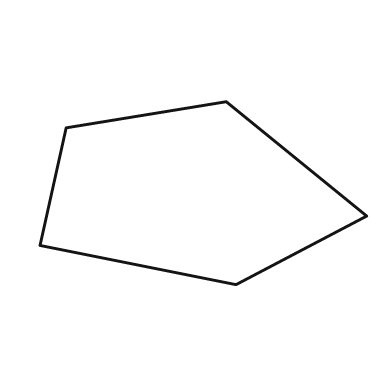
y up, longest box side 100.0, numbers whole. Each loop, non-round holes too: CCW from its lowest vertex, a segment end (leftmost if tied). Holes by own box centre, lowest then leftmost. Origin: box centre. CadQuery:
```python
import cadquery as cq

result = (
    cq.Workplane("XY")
    .moveTo(10.0, -28.0)
    .lineTo(50.0, -7.0)
    .lineTo(7.0, 28.0)
    .lineTo(-42.0, 20.0)
    .lineTo(-50.0, -16.0)
    .close()
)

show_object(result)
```